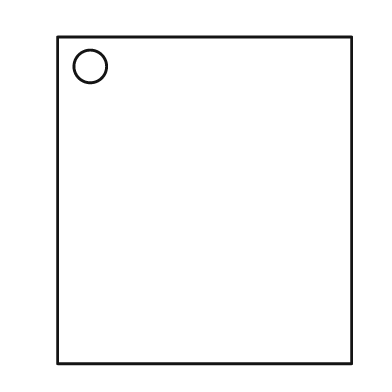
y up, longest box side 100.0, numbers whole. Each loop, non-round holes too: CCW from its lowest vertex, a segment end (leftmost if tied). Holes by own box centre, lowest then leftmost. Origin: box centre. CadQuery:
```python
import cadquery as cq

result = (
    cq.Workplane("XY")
    .moveTo(-45.0, -50.0)
    .lineTo(45.0, -50.0)
    .lineTo(45.0, 50.0)
    .lineTo(-45.0, 50.0)
    .close()
    .moveTo(-35.0, 41.0)
    .circle(5.0)
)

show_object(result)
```